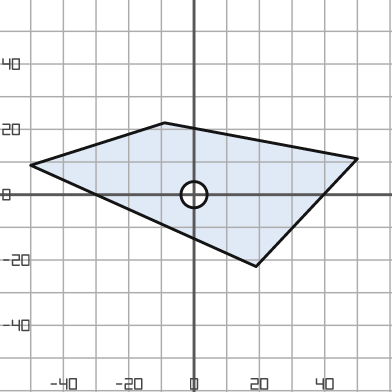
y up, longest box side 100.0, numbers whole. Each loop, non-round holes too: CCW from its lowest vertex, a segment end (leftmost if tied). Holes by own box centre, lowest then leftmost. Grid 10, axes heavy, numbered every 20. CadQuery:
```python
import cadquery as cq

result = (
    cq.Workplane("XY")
    .moveTo(19.0, -22.0)
    .lineTo(50.0, 11.0)
    .lineTo(-9.0, 22.0)
    .lineTo(-50.0, 9.0)
    .close()
    .moveTo(0.0, 0.0)
    .circle(4.0)
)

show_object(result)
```